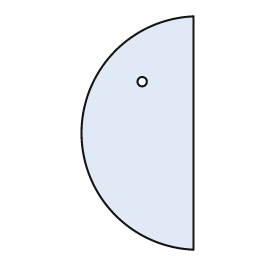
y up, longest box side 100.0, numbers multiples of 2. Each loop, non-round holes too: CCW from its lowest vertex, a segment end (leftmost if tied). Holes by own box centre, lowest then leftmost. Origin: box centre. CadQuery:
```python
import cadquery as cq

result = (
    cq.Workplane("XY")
    .moveTo(24.0, -50.0)
    .lineTo(24.0, 50.0)
    .threePointArc((-24.0, 0.0), (24.0, -50.0))
    .close()
    .moveTo(2.0, 22.0)
    .circle(2.0)
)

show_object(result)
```